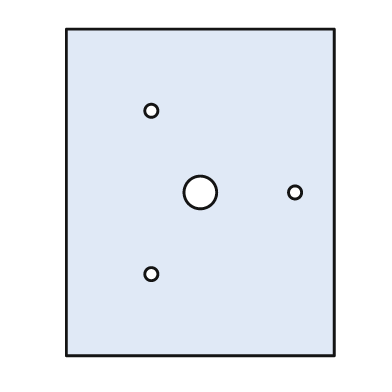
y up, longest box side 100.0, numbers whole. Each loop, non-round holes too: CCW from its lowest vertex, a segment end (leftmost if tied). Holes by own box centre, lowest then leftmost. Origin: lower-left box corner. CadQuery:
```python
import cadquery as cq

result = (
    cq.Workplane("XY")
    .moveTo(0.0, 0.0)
    .lineTo(82.0, 0.0)
    .lineTo(82.0, 100.0)
    .lineTo(0.0, 100.0)
    .close()
    .moveTo(26.0, 25.0)
    .circle(2.0)
    .moveTo(41.0, 50.0)
    .circle(5.0)
    .moveTo(70.0, 50.0)
    .circle(2.0)
    .moveTo(26.0, 75.0)
    .circle(2.0)
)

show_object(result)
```